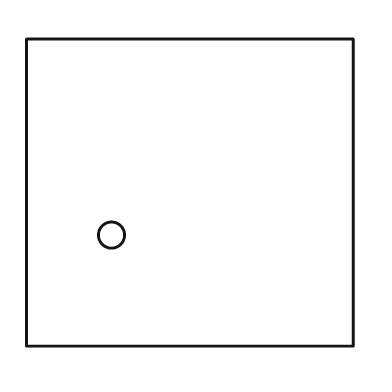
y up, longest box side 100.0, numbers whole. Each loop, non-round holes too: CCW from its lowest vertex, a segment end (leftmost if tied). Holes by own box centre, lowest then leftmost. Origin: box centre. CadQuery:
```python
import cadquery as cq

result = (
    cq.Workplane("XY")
    .moveTo(-50.0, -47.0)
    .lineTo(50.0, -47.0)
    .lineTo(50.0, 47.0)
    .lineTo(-50.0, 47.0)
    .close()
    .moveTo(-24.0, -13.0)
    .circle(4.0)
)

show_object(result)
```